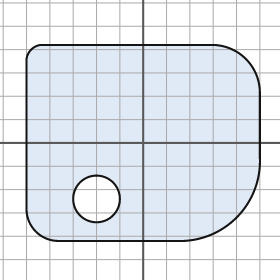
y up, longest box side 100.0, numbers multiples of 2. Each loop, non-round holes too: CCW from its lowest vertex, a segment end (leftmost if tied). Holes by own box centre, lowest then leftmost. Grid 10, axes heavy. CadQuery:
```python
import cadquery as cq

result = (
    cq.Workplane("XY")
    .moveTo(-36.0, -42.0)
    .lineTo(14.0, -42.0)
    .threePointArc((40.0, -32.0), (50.0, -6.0))
    .lineTo(50.0, 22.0)
    .threePointArc((44.0, 36.0), (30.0, 42.0))
    .lineTo(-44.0, 42.0)
    .threePointArc((-48.0, 40.0), (-50.0, 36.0))
    .lineTo(-50.0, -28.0)
    .threePointArc((-46.0, -38.0), (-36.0, -42.0))
    .close()
    .moveTo(-20.0, -24.0)
    .circle(10.0)
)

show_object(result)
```